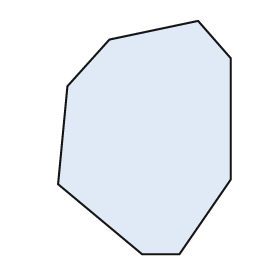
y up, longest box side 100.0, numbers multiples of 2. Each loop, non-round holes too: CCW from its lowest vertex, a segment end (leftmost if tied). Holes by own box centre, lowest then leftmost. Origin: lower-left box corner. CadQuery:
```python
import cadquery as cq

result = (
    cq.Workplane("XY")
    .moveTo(36.0, 0.0)
    .lineTo(52.0, 0.0)
    .lineTo(74.0, 32.0)
    .lineTo(74.0, 84.0)
    .lineTo(60.0, 100.0)
    .lineTo(22.0, 92.0)
    .lineTo(4.0, 72.0)
    .lineTo(0.0, 30.0)
    .close()
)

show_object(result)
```